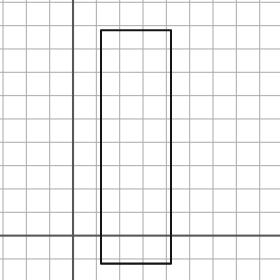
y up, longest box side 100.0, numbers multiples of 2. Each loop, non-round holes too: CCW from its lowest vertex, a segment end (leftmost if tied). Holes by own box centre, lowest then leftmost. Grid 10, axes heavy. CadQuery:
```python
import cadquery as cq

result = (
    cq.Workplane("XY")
    .moveTo(12.0, -12.0)
    .lineTo(42.0, -12.0)
    .lineTo(42.0, 88.0)
    .lineTo(12.0, 88.0)
    .close()
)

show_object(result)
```